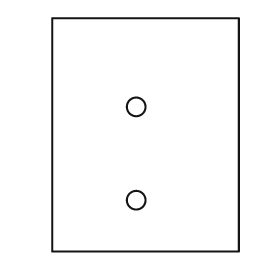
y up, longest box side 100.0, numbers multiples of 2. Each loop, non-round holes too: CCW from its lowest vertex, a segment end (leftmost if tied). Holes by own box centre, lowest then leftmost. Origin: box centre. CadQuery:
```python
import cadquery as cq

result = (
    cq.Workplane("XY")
    .moveTo(-40.0, -50.0)
    .lineTo(40.0, -50.0)
    .lineTo(40.0, 50.0)
    .lineTo(-40.0, 50.0)
    .close()
    .moveTo(-4.0, -28.0)
    .circle(4.0)
    .moveTo(-4.0, 12.0)
    .circle(4.0)
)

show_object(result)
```